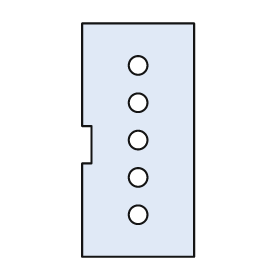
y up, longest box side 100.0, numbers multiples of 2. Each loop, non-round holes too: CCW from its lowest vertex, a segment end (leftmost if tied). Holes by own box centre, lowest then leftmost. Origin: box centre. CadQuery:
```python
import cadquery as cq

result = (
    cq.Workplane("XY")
    .moveTo(-24.0, -50.0)
    .lineTo(24.0, -50.0)
    .lineTo(24.0, 50.0)
    .lineTo(-24.0, 50.0)
    .lineTo(-24.0, 6.0)
    .lineTo(-20.0, 6.0)
    .lineTo(-20.0, -10.0)
    .lineTo(-24.0, -10.0)
    .close()
    .moveTo(0.0, -32.0)
    .circle(4.0)
    .moveTo(0.0, -16.0)
    .circle(4.0)
    .moveTo(0.0, 0.0)
    .circle(4.0)
    .moveTo(0.0, 16.0)
    .circle(4.0)
    .moveTo(0.0, 32.0)
    .circle(4.0)
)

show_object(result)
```